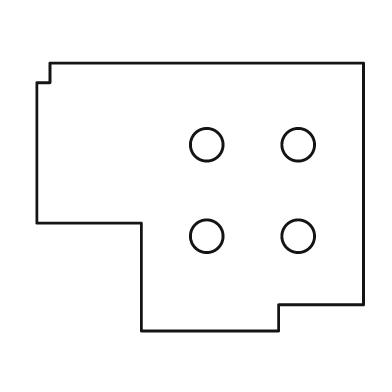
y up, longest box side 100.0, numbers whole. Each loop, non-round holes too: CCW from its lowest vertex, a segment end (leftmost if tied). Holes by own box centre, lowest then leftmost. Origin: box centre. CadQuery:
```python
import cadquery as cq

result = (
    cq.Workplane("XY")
    .moveTo(-18.0, -41.0)
    .lineTo(24.0, -41.0)
    .lineTo(24.0, -33.0)
    .lineTo(50.0, -33.0)
    .lineTo(50.0, 41.0)
    .lineTo(-46.0, 41.0)
    .lineTo(-46.0, 35.0)
    .lineTo(-50.0, 35.0)
    .lineTo(-50.0, -8.0)
    .lineTo(-18.0, -8.0)
    .close()
    .moveTo(2.0, -12.0)
    .circle(5.0)
    .moveTo(30.0, -12.0)
    .circle(5.0)
    .moveTo(2.0, 16.0)
    .circle(5.0)
    .moveTo(30.0, 16.0)
    .circle(5.0)
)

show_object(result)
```